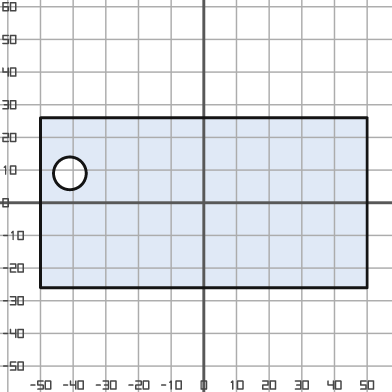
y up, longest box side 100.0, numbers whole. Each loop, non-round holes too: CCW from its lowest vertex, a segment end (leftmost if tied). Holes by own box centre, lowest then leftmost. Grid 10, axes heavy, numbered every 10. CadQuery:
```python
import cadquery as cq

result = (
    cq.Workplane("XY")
    .moveTo(-50.0, -26.0)
    .lineTo(50.0, -26.0)
    .lineTo(50.0, 26.0)
    .lineTo(-50.0, 26.0)
    .close()
    .moveTo(-41.0, 9.0)
    .circle(5.0)
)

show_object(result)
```